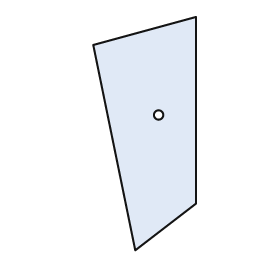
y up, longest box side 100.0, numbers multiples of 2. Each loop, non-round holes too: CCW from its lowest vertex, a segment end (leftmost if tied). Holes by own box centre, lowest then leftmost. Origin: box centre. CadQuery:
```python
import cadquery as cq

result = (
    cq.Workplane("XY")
    .moveTo(-4.0, -50.0)
    .lineTo(22.0, -30.0)
    .lineTo(22.0, 50.0)
    .lineTo(-22.0, 38.0)
    .close()
    .moveTo(6.0, 8.0)
    .circle(2.0)
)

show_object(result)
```